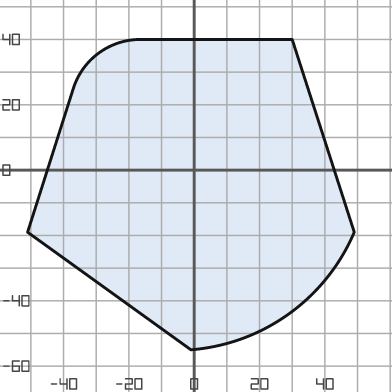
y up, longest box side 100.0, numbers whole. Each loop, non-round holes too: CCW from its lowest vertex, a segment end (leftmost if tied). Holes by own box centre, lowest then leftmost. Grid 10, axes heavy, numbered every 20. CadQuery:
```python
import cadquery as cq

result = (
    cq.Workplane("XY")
    .moveTo(-1.0, -55.0)
    .threePointArc((29.0, -44.0), (49.0, -19.0))
    .lineTo(30.0, 40.0)
    .lineTo(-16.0, 40.0)
    .threePointArc((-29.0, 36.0), (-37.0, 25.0))
    .lineTo(-51.0, -19.0)
    .close()
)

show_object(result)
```